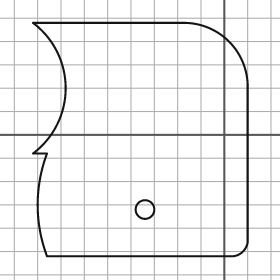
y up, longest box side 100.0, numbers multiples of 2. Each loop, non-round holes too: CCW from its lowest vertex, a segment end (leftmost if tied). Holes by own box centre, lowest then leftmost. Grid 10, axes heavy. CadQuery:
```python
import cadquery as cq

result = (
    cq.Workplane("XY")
    .moveTo(-76.0, -52.0)
    .lineTo(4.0, -52.0)
    .threePointArc((8.0, -50.0), (10.0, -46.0))
    .lineTo(10.0, 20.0)
    .threePointArc((2.0, 40.0), (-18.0, 48.0))
    .lineTo(-82.0, 48.0)
    .threePointArc((-68.0, 20.0), (-82.0, -8.0))
    .lineTo(-76.0, -8.0)
    .threePointArc((-80.0, -30.0), (-76.0, -52.0))
    .close()
    .moveTo(-34.0, -32.0)
    .circle(4.0)
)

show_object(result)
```